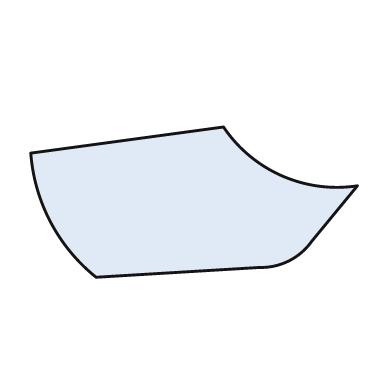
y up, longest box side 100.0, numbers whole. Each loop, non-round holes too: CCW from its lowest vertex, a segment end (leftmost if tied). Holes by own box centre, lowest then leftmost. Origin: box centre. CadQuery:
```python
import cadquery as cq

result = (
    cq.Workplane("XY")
    .moveTo(-30.0, -23.0)
    .lineTo(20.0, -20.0)
    .threePointArc((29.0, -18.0), (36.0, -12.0))
    .lineTo(50.0, 5.0)
    .threePointArc((27.0, 8.0), (9.0, 23.0))
    .lineTo(-50.0, 15.0)
    .threePointArc((-44.0, -6.0), (-30.0, -23.0))
    .close()
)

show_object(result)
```